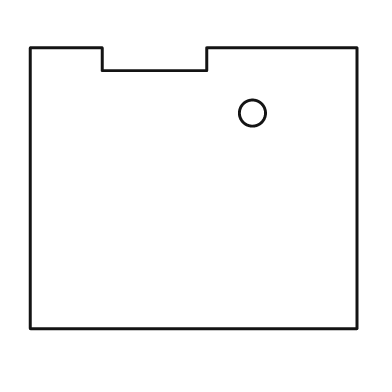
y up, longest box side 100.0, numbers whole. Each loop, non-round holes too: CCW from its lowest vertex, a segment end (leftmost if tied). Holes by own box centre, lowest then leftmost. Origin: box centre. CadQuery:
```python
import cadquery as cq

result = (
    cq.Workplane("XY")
    .moveTo(-50.0, -43.0)
    .lineTo(50.0, -43.0)
    .lineTo(50.0, 43.0)
    .lineTo(4.0, 43.0)
    .lineTo(4.0, 36.0)
    .lineTo(-28.0, 36.0)
    .lineTo(-28.0, 43.0)
    .lineTo(-50.0, 43.0)
    .close()
    .moveTo(18.0, 23.0)
    .circle(4.0)
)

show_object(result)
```